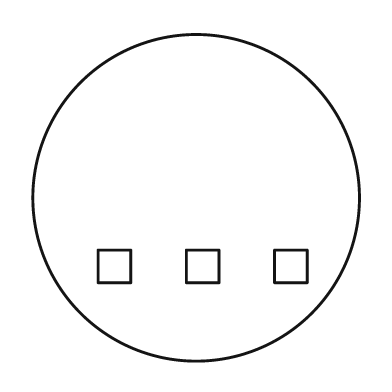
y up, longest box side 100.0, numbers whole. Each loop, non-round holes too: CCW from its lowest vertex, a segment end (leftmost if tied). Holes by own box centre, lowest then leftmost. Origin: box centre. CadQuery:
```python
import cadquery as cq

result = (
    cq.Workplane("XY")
    .moveTo(0.0, 0.0)
    .circle(50.0)
    .moveTo(-30.0, -26.0)
    .lineTo(-20.0, -26.0)
    .lineTo(-20.0, -16.0)
    .lineTo(-30.0, -16.0)
    .close()
    .moveTo(-3.0, -26.0)
    .lineTo(7.0, -26.0)
    .lineTo(7.0, -16.0)
    .lineTo(-3.0, -16.0)
    .close()
    .moveTo(24.0, -26.0)
    .lineTo(34.0, -26.0)
    .lineTo(34.0, -16.0)
    .lineTo(24.0, -16.0)
    .close()
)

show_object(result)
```